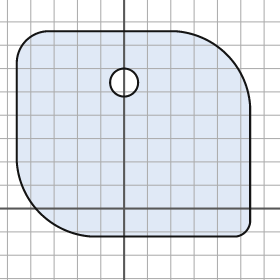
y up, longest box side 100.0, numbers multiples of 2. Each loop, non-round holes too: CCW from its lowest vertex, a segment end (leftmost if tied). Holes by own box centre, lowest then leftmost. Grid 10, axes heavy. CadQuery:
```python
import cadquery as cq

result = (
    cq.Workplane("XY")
    .moveTo(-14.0, -12.0)
    .lineTo(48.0, -12.0)
    .threePointArc((52.0, -10.0), (54.0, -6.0))
    .lineTo(54.0, 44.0)
    .threePointArc((44.0, 66.0), (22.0, 76.0))
    .lineTo(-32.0, 76.0)
    .threePointArc((-42.0, 72.0), (-46.0, 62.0))
    .lineTo(-46.0, 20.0)
    .threePointArc((-36.0, -2.0), (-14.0, -12.0))
    .close()
    .moveTo(0.0, 54.0)
    .circle(6.0)
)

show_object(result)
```